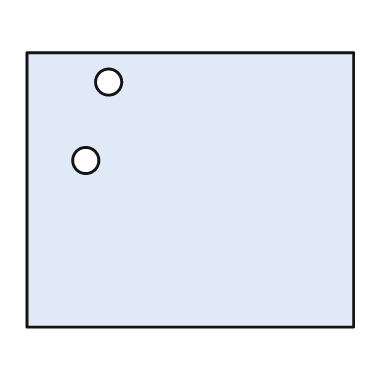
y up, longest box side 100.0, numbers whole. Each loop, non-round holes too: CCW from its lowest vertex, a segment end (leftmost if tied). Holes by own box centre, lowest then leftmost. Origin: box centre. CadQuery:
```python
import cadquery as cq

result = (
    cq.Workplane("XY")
    .moveTo(-50.0, -42.0)
    .lineTo(50.0, -42.0)
    .lineTo(50.0, 42.0)
    .lineTo(-50.0, 42.0)
    .close()
    .moveTo(-32.0, 9.0)
    .circle(4.0)
    .moveTo(-25.0, 33.0)
    .circle(4.0)
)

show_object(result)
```